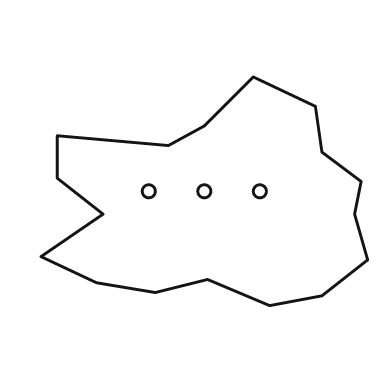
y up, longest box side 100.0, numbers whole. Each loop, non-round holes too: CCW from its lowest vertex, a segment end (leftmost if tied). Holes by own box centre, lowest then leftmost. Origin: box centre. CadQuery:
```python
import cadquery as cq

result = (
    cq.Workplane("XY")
    .moveTo(20.0, -35.0)
    .lineTo(36.0, -32.0)
    .lineTo(50.0, -21.0)
    .lineTo(46.0, -7.0)
    .lineTo(48.0, 3.0)
    .lineTo(36.0, 12.0)
    .lineTo(34.0, 26.0)
    .lineTo(15.0, 35.0)
    .lineTo(0.0, 20.0)
    .lineTo(-11.0, 14.0)
    .lineTo(-45.0, 17.0)
    .lineTo(-45.0, 4.0)
    .lineTo(-31.0, -7.0)
    .lineTo(-50.0, -20.0)
    .lineTo(-33.0, -28.0)
    .lineTo(-15.0, -31.0)
    .lineTo(1.0, -27.0)
    .close()
    .moveTo(-17.0, 0.0)
    .circle(2.0)
    .moveTo(0.0, 0.0)
    .circle(2.0)
    .moveTo(17.0, 0.0)
    .circle(2.0)
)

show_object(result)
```